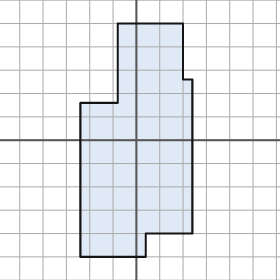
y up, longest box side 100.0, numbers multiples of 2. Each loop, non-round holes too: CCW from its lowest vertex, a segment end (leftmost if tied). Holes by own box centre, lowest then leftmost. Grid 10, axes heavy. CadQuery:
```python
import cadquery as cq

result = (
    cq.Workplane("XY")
    .moveTo(-24.0, -50.0)
    .lineTo(4.0, -50.0)
    .lineTo(4.0, -40.0)
    .lineTo(24.0, -40.0)
    .lineTo(24.0, 26.0)
    .lineTo(20.0, 26.0)
    .lineTo(20.0, 50.0)
    .lineTo(-8.0, 50.0)
    .lineTo(-8.0, 16.0)
    .lineTo(-24.0, 16.0)
    .close()
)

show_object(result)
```